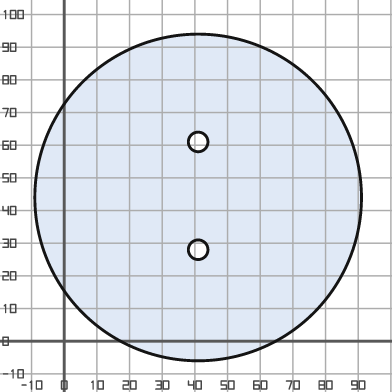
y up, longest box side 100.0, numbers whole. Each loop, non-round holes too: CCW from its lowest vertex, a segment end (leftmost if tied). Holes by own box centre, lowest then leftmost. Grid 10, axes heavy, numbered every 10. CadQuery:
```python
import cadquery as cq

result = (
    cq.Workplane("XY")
    .moveTo(41.0, 44.0)
    .circle(50.0)
    .moveTo(41.0, 28.0)
    .circle(3.0)
    .moveTo(41.0, 61.0)
    .circle(3.0)
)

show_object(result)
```